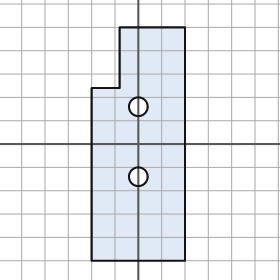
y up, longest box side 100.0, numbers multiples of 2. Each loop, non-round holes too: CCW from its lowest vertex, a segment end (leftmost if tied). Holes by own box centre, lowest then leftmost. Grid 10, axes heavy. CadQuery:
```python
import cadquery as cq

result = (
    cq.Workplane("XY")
    .moveTo(-20.0, -50.0)
    .lineTo(20.0, -50.0)
    .lineTo(20.0, 50.0)
    .lineTo(-8.0, 50.0)
    .lineTo(-8.0, 24.0)
    .lineTo(-20.0, 24.0)
    .close()
    .moveTo(0.0, -14.0)
    .circle(4.0)
    .moveTo(0.0, 16.0)
    .circle(4.0)
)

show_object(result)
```